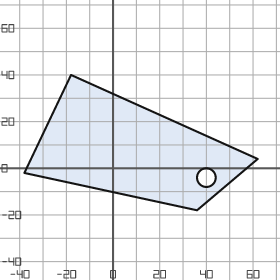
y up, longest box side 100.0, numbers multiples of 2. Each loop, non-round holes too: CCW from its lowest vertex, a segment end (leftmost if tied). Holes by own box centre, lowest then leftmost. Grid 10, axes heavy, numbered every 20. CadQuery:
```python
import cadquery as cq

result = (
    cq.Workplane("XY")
    .moveTo(36.0, -18.0)
    .lineTo(62.0, 4.0)
    .lineTo(-18.0, 40.0)
    .lineTo(-38.0, -2.0)
    .close()
    .moveTo(40.0, -4.0)
    .circle(4.0)
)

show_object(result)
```